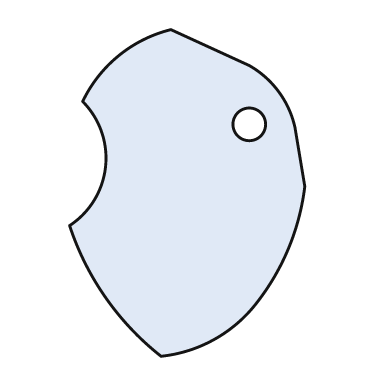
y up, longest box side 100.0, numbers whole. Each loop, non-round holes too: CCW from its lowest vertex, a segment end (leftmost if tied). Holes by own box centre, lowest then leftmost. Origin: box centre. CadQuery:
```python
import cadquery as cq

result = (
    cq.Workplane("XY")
    .moveTo(-8.0, -50.0)
    .threePointArc((8.0, -45.0), (21.0, -34.0))
    .threePointArc((31.0, -17.0), (36.0, 2.0))
    .lineTo(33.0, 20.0)
    .threePointArc((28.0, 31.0), (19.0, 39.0))
    .lineTo(-5.0, 50.0)
    .threePointArc((-21.0, 42.0), (-32.0, 28.0))
    .threePointArc((-25.0, 8.0), (-36.0, -10.0))
    .threePointArc((-25.0, -32.0), (-8.0, -50.0))
    .close()
    .moveTo(19.0, 21.0)
    .circle(5.0)
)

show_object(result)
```